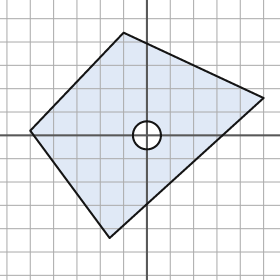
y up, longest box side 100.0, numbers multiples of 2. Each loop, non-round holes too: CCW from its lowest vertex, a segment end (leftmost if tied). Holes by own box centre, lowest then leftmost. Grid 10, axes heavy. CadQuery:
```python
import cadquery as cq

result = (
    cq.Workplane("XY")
    .moveTo(-16.0, -44.0)
    .lineTo(50.0, 16.0)
    .lineTo(-10.0, 44.0)
    .lineTo(-50.0, 2.0)
    .close()
    .moveTo(0.0, 0.0)
    .circle(6.0)
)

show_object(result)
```